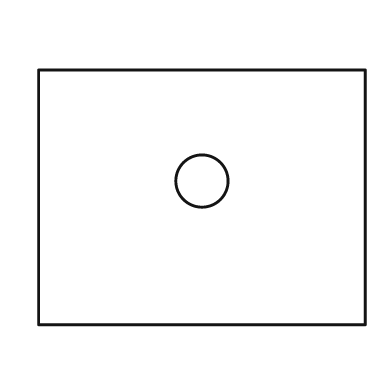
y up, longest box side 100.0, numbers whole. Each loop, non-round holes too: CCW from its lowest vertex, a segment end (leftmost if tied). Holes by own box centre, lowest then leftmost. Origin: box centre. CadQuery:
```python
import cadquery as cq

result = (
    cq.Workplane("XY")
    .moveTo(-50.0, -39.0)
    .lineTo(50.0, -39.0)
    .lineTo(50.0, 39.0)
    .lineTo(-50.0, 39.0)
    .close()
    .moveTo(0.0, 5.0)
    .circle(8.0)
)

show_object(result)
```